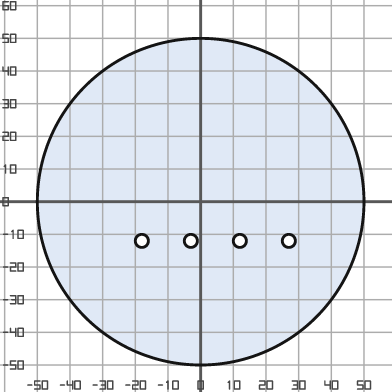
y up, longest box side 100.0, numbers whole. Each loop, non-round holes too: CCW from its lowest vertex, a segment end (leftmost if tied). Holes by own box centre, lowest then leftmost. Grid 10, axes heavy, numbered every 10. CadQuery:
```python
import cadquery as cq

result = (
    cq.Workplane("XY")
    .moveTo(0.0, 0.0)
    .circle(50.0)
    .moveTo(-18.0, -12.0)
    .circle(2.0)
    .moveTo(-3.0, -12.0)
    .circle(2.0)
    .moveTo(12.0, -12.0)
    .circle(2.0)
    .moveTo(27.0, -12.0)
    .circle(2.0)
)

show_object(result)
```